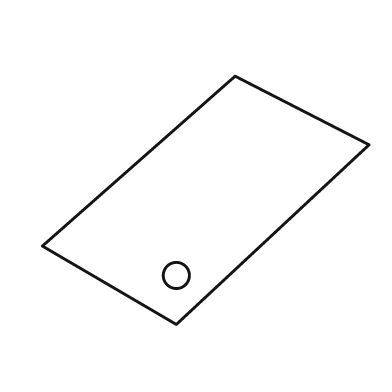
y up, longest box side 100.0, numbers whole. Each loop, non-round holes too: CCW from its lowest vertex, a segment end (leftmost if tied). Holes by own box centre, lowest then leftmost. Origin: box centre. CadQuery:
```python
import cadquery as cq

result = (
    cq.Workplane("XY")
    .moveTo(-9.0, -38.0)
    .lineTo(50.0, 17.0)
    .lineTo(9.0, 38.0)
    .lineTo(-50.0, -14.0)
    .close()
    .moveTo(-9.0, -23.0)
    .circle(4.0)
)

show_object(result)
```